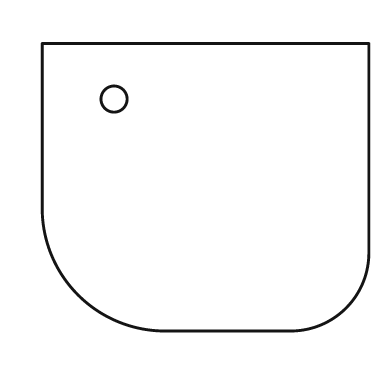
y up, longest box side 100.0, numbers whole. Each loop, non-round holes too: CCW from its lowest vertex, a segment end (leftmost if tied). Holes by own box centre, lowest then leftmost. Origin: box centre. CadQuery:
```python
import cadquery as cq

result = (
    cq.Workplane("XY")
    .moveTo(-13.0, -44.0)
    .lineTo(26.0, -44.0)
    .threePointArc((43.0, -37.0), (50.0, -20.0))
    .lineTo(50.0, 44.0)
    .lineTo(-50.0, 44.0)
    .lineTo(-50.0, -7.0)
    .threePointArc((-39.0, -33.0), (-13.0, -44.0))
    .close()
    .moveTo(-28.0, 27.0)
    .circle(4.0)
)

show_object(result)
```